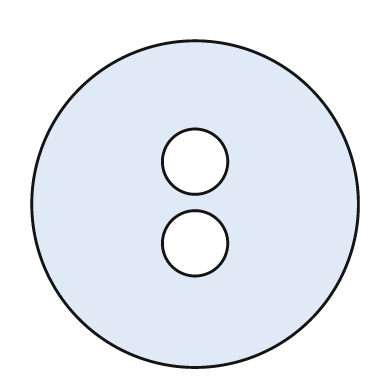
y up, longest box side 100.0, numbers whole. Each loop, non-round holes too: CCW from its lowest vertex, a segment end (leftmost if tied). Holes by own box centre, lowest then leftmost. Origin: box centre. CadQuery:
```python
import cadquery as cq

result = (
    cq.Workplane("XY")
    .moveTo(0.0, 0.0)
    .circle(50.0)
    .moveTo(0.0, -12.0)
    .circle(10.0)
    .moveTo(0.0, 13.0)
    .circle(10.0)
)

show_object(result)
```